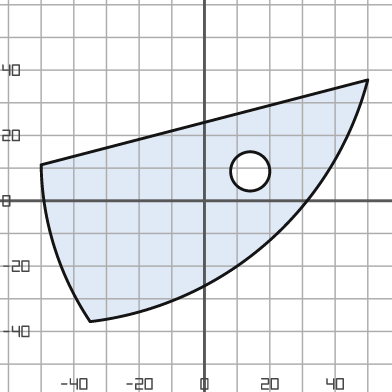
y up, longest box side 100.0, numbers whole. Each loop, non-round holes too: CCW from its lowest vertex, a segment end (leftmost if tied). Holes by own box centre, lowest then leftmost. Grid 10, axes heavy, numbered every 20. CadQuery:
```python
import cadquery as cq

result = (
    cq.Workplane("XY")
    .moveTo(-35.0, -37.0)
    .threePointArc((19.0, -13.0), (50.0, 37.0))
    .lineTo(-50.0, 11.0)
    .threePointArc((-46.0, -14.0), (-35.0, -37.0))
    .close()
    .moveTo(14.0, 9.0)
    .circle(6.0)
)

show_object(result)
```